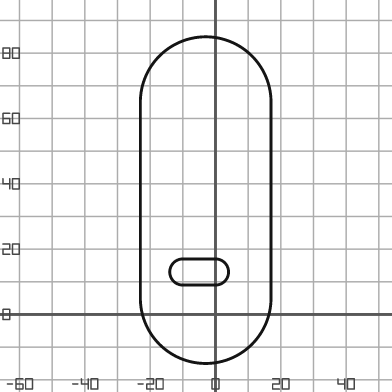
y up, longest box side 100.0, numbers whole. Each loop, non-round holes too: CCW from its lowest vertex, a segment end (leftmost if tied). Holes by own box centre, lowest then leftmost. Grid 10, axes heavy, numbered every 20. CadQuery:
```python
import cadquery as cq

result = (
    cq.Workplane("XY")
    .moveTo(-23.0, 5.0)
    .threePointArc((-3.0, -15.0), (17.0, 5.0))
    .lineTo(17.0, 65.0)
    .threePointArc((-3.0, 85.0), (-23.0, 65.0))
    .close()
    .moveTo(-10.0, 9.0)
    .lineTo(0.0, 9.0)
    .threePointArc((4.0, 13.0), (0.0, 17.0))
    .lineTo(-10.0, 17.0)
    .threePointArc((-14.0, 13.0), (-10.0, 9.0))
    .close()
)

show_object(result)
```